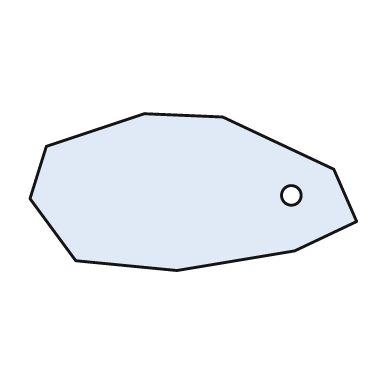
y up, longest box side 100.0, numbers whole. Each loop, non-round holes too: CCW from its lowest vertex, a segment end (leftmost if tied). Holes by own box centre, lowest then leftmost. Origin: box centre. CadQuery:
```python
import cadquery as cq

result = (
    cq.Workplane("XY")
    .moveTo(-5.0, -24.0)
    .lineTo(31.0, -18.0)
    .lineTo(50.0, -9.0)
    .lineTo(43.0, 7.0)
    .lineTo(9.0, 23.0)
    .lineTo(-15.0, 24.0)
    .lineTo(-45.0, 14.0)
    .lineTo(-50.0, -2.0)
    .lineTo(-36.0, -21.0)
    .close()
    .moveTo(30.0, -1.0)
    .circle(3.0)
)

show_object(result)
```